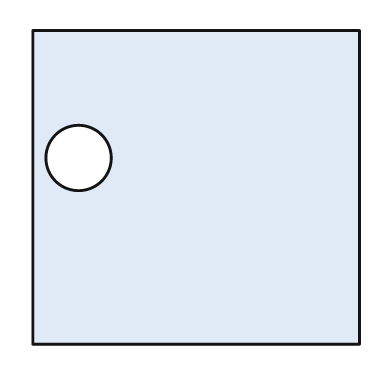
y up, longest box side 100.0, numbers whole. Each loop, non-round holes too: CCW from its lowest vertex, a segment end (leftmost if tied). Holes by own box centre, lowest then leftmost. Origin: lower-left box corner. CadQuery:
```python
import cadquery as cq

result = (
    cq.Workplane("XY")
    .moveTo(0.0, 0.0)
    .lineTo(100.0, 0.0)
    .lineTo(100.0, 96.0)
    .lineTo(0.0, 96.0)
    .close()
    .moveTo(14.0, 57.0)
    .circle(10.0)
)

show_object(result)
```